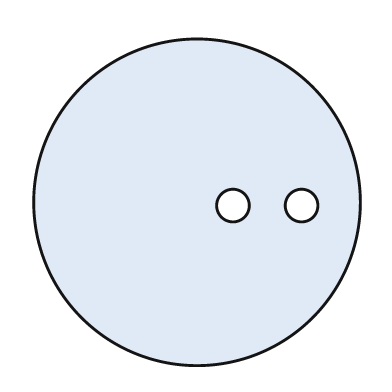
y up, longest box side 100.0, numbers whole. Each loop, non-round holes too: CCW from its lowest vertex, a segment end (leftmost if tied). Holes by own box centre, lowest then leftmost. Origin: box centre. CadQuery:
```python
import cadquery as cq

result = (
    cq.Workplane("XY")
    .moveTo(0.0, 0.0)
    .circle(50.0)
    .moveTo(11.0, -1.0)
    .circle(5.0)
    .moveTo(32.0, -1.0)
    .circle(5.0)
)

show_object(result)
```